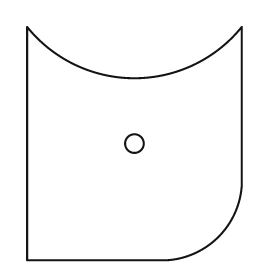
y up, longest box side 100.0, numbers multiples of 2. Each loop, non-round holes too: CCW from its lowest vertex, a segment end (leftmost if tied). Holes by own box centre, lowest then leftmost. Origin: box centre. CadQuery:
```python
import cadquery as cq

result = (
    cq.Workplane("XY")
    .moveTo(-46.0, -50.0)
    .lineTo(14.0, -50.0)
    .threePointArc((36.0, -40.0), (46.0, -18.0))
    .lineTo(46.0, 50.0)
    .threePointArc((0.0, 28.0), (-46.0, 50.0))
    .close()
    .moveTo(0.0, 0.0)
    .circle(4.0)
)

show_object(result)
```